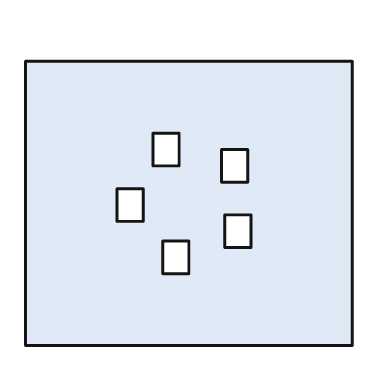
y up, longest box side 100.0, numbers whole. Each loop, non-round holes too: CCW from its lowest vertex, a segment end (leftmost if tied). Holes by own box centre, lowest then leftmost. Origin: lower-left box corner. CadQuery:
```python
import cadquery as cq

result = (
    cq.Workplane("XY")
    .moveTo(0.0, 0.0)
    .lineTo(100.0, 0.0)
    .lineTo(100.0, 87.0)
    .lineTo(0.0, 87.0)
    .close()
    .moveTo(42.0, 22.0)
    .lineTo(50.0, 22.0)
    .lineTo(50.0, 32.0)
    .lineTo(42.0, 32.0)
    .close()
    .moveTo(61.0, 30.0)
    .lineTo(69.0, 30.0)
    .lineTo(69.0, 40.0)
    .lineTo(61.0, 40.0)
    .close()
    .moveTo(28.0, 38.0)
    .lineTo(36.0, 38.0)
    .lineTo(36.0, 48.0)
    .lineTo(28.0, 48.0)
    .close()
    .moveTo(60.0, 50.0)
    .lineTo(68.0, 50.0)
    .lineTo(68.0, 60.0)
    .lineTo(60.0, 60.0)
    .close()
    .moveTo(39.0, 55.0)
    .lineTo(47.0, 55.0)
    .lineTo(47.0, 65.0)
    .lineTo(39.0, 65.0)
    .close()
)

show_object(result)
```